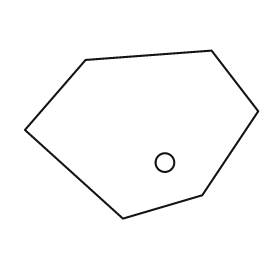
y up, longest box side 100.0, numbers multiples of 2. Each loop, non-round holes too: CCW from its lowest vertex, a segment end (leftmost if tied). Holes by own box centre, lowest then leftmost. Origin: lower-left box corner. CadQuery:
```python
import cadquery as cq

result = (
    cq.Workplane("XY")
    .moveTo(42.0, 0.0)
    .lineTo(76.0, 10.0)
    .lineTo(100.0, 46.0)
    .lineTo(80.0, 72.0)
    .lineTo(26.0, 68.0)
    .lineTo(0.0, 38.0)
    .close()
    .moveTo(60.0, 24.0)
    .circle(4.0)
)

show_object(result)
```